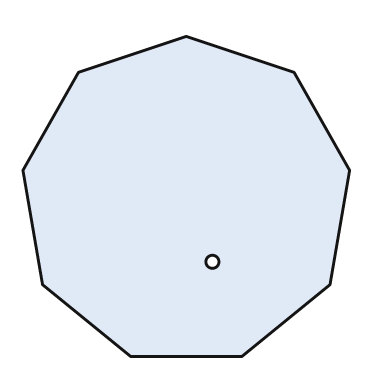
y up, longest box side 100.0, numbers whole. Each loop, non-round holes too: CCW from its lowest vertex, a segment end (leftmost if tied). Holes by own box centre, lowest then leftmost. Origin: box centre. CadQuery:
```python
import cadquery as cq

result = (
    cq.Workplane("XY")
    .moveTo(-17.0, -49.0)
    .lineTo(17.0, -49.0)
    .lineTo(44.0, -27.0)
    .lineTo(50.0, 8.0)
    .lineTo(33.0, 38.0)
    .lineTo(0.0, 49.0)
    .lineTo(-33.0, 38.0)
    .lineTo(-50.0, 8.0)
    .lineTo(-44.0, -27.0)
    .close()
    .moveTo(8.0, -20.0)
    .circle(2.0)
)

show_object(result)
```